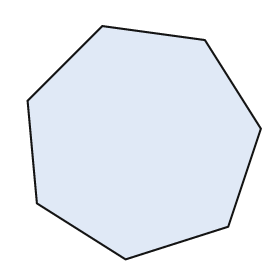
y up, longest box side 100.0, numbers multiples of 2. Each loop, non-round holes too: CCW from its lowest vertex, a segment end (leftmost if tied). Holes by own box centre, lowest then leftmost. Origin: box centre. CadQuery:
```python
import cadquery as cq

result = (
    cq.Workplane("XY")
    .moveTo(-8.0, -50.0)
    .lineTo(36.0, -36.0)
    .lineTo(50.0, 6.0)
    .lineTo(26.0, 44.0)
    .lineTo(-18.0, 50.0)
    .lineTo(-50.0, 18.0)
    .lineTo(-46.0, -26.0)
    .close()
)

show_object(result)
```